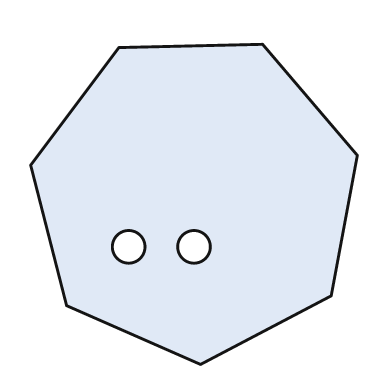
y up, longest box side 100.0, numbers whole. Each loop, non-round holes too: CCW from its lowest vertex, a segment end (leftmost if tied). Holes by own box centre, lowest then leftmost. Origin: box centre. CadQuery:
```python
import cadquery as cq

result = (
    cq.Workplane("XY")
    .moveTo(2.0, -49.0)
    .lineTo(42.0, -28.0)
    .lineTo(50.0, 15.0)
    .lineTo(21.0, 49.0)
    .lineTo(-23.0, 48.0)
    .lineTo(-50.0, 12.0)
    .lineTo(-39.0, -31.0)
    .close()
    .moveTo(-20.0, -13.0)
    .circle(5.0)
    .moveTo(0.0, -13.0)
    .circle(5.0)
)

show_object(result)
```